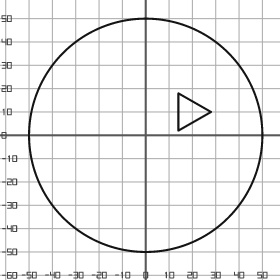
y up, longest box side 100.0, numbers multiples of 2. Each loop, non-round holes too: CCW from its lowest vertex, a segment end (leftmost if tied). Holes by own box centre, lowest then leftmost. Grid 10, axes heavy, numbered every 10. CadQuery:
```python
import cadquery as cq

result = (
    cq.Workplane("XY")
    .moveTo(0.0, 0.0)
    .circle(50.0)
    .moveTo(14.0, 2.0)
    .lineTo(28.0, 10.0)
    .lineTo(14.0, 18.0)
    .close()
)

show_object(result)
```